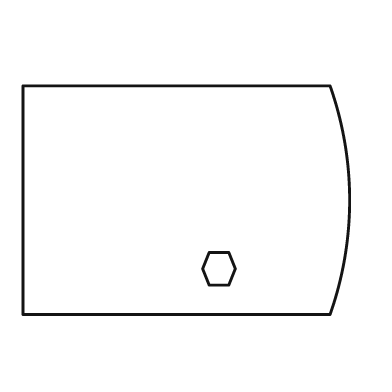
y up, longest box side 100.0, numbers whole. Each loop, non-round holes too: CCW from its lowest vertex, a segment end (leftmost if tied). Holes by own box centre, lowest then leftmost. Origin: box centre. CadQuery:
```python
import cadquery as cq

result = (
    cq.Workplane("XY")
    .moveTo(-50.0, -35.0)
    .lineTo(44.0, -35.0)
    .threePointArc((50.0, 0.0), (44.0, 35.0))
    .lineTo(-50.0, 35.0)
    .close()
    .moveTo(7.0, -26.0)
    .lineTo(13.0, -26.0)
    .lineTo(15.0, -21.0)
    .lineTo(13.0, -16.0)
    .lineTo(7.0, -16.0)
    .lineTo(5.0, -21.0)
    .close()
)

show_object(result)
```